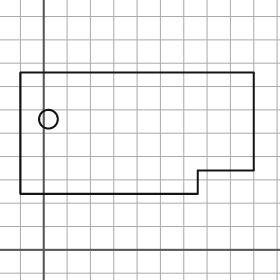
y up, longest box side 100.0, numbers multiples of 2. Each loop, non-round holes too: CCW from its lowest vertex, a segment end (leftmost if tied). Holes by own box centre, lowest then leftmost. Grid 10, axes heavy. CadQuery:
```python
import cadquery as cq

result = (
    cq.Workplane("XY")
    .moveTo(-10.0, 24.0)
    .lineTo(66.0, 24.0)
    .lineTo(66.0, 34.0)
    .lineTo(90.0, 34.0)
    .lineTo(90.0, 76.0)
    .lineTo(-10.0, 76.0)
    .close()
    .moveTo(2.0, 56.0)
    .circle(4.0)
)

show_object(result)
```